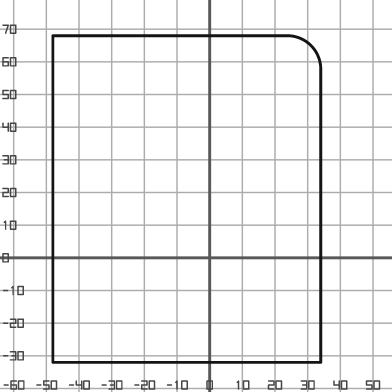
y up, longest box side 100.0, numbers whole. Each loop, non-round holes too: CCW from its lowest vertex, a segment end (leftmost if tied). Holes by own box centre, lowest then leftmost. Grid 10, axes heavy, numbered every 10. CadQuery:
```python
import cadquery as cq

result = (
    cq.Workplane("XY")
    .moveTo(-48.0, -32.0)
    .lineTo(34.0, -32.0)
    .lineTo(34.0, 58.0)
    .threePointArc((31.0, 65.0), (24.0, 68.0))
    .lineTo(-48.0, 68.0)
    .close()
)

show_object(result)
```